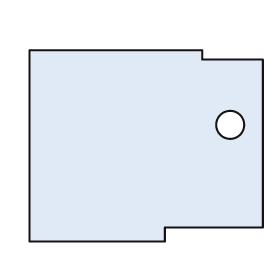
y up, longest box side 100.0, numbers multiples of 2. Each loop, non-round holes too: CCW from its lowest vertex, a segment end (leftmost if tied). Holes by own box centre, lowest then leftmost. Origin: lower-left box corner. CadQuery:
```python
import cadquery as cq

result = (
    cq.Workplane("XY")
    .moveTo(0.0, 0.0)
    .lineTo(58.0, 0.0)
    .lineTo(58.0, 6.0)
    .lineTo(100.0, 6.0)
    .lineTo(100.0, 78.0)
    .lineTo(74.0, 78.0)
    .lineTo(74.0, 82.0)
    .lineTo(0.0, 82.0)
    .close()
    .moveTo(86.0, 50.0)
    .circle(6.0)
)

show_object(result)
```